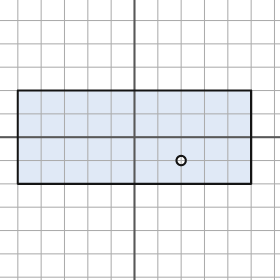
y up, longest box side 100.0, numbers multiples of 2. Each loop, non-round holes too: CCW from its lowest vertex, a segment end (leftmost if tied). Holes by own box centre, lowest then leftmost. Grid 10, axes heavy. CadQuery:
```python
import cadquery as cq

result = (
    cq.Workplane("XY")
    .moveTo(-50.0, -20.0)
    .lineTo(50.0, -20.0)
    .lineTo(50.0, 20.0)
    .lineTo(-50.0, 20.0)
    .close()
    .moveTo(20.0, -10.0)
    .circle(2.0)
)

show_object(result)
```